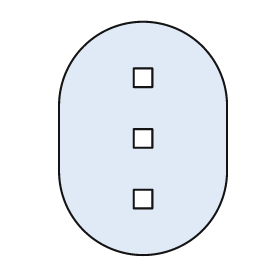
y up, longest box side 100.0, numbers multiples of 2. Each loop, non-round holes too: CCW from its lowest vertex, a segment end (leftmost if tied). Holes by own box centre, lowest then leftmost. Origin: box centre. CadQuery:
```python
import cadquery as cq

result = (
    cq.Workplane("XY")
    .moveTo(-36.0, -14.0)
    .threePointArc((0.0, -50.0), (36.0, -14.0))
    .lineTo(36.0, 14.0)
    .threePointArc((0.0, 50.0), (-36.0, 14.0))
    .close()
    .moveTo(-4.0, -30.0)
    .lineTo(4.0, -30.0)
    .lineTo(4.0, -22.0)
    .lineTo(-4.0, -22.0)
    .close()
    .moveTo(-4.0, -4.0)
    .lineTo(4.0, -4.0)
    .lineTo(4.0, 4.0)
    .lineTo(-4.0, 4.0)
    .close()
    .moveTo(-4.0, 22.0)
    .lineTo(4.0, 22.0)
    .lineTo(4.0, 30.0)
    .lineTo(-4.0, 30.0)
    .close()
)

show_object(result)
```